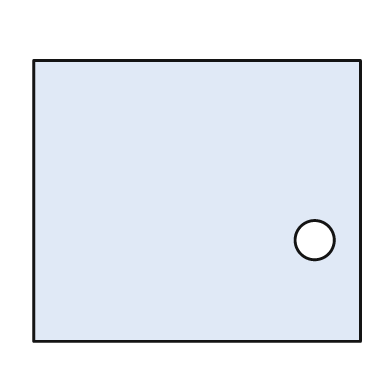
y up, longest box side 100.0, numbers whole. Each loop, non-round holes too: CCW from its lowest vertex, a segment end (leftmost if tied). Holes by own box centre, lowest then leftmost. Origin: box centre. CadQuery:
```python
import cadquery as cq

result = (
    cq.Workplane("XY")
    .moveTo(-50.0, -43.0)
    .lineTo(50.0, -43.0)
    .lineTo(50.0, 43.0)
    .lineTo(-50.0, 43.0)
    .close()
    .moveTo(36.0, -12.0)
    .circle(6.0)
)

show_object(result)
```